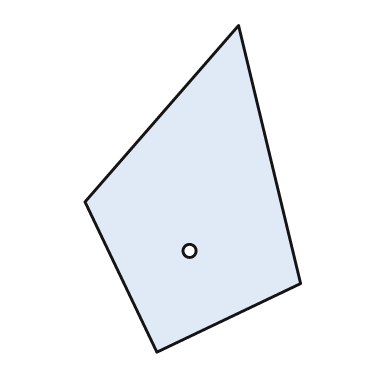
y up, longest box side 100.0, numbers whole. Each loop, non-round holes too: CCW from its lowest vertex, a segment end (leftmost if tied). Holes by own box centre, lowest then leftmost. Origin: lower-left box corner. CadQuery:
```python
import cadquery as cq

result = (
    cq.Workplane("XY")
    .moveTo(22.0, 0.0)
    .lineTo(66.0, 21.0)
    .lineTo(47.0, 100.0)
    .lineTo(0.0, 46.0)
    .close()
    .moveTo(32.0, 31.0)
    .circle(2.0)
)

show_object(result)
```